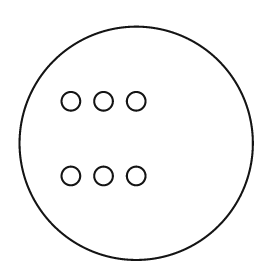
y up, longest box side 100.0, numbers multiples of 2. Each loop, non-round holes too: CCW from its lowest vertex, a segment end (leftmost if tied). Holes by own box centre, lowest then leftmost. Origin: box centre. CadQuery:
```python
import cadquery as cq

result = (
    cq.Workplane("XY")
    .moveTo(0.0, 0.0)
    .circle(50.0)
    .moveTo(-28.0, -14.0)
    .circle(4.0)
    .moveTo(-14.0, -14.0)
    .circle(4.0)
    .moveTo(0.0, -14.0)
    .circle(4.0)
    .moveTo(-28.0, 18.0)
    .circle(4.0)
    .moveTo(-14.0, 18.0)
    .circle(4.0)
    .moveTo(0.0, 18.0)
    .circle(4.0)
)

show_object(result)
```